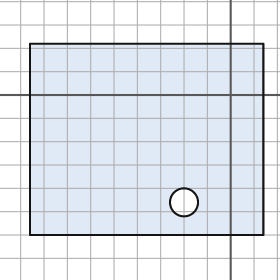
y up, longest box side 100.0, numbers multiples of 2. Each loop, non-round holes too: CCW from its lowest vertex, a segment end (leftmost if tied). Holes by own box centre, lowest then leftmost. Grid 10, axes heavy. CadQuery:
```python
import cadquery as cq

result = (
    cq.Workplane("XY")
    .moveTo(-86.0, -60.0)
    .lineTo(14.0, -60.0)
    .lineTo(14.0, 22.0)
    .lineTo(-86.0, 22.0)
    .close()
    .moveTo(-20.0, -46.0)
    .circle(6.0)
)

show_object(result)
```